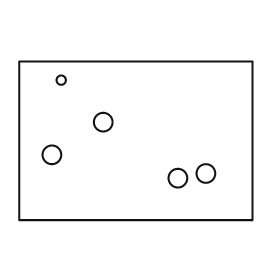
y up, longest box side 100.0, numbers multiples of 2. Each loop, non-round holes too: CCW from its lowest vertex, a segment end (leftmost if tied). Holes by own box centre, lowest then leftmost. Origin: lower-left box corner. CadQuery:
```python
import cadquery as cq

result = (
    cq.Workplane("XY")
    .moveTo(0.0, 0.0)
    .lineTo(100.0, 0.0)
    .lineTo(100.0, 68.0)
    .lineTo(0.0, 68.0)
    .close()
    .moveTo(68.0, 18.0)
    .circle(4.0)
    .moveTo(80.0, 20.0)
    .circle(4.0)
    .moveTo(14.0, 28.0)
    .circle(4.0)
    .moveTo(36.0, 42.0)
    .circle(4.0)
    .moveTo(18.0, 60.0)
    .circle(2.0)
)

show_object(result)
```